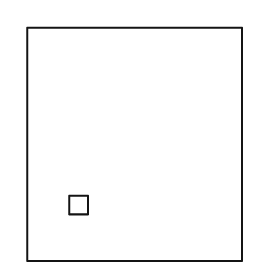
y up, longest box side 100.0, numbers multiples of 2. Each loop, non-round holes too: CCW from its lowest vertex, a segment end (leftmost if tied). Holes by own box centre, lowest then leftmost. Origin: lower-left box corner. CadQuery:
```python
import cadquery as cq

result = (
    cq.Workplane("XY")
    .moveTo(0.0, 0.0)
    .lineTo(92.0, 0.0)
    .lineTo(92.0, 100.0)
    .lineTo(0.0, 100.0)
    .close()
    .moveTo(18.0, 20.0)
    .lineTo(26.0, 20.0)
    .lineTo(26.0, 28.0)
    .lineTo(18.0, 28.0)
    .close()
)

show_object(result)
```